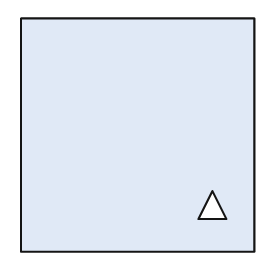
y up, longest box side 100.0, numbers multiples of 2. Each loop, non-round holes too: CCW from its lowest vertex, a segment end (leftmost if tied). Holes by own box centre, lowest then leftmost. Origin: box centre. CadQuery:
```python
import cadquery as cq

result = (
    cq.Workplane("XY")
    .moveTo(-50.0, -50.0)
    .lineTo(50.0, -50.0)
    .lineTo(50.0, 50.0)
    .lineTo(-50.0, 50.0)
    .close()
    .moveTo(26.0, -36.0)
    .lineTo(38.0, -36.0)
    .lineTo(32.0, -24.0)
    .close()
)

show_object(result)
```